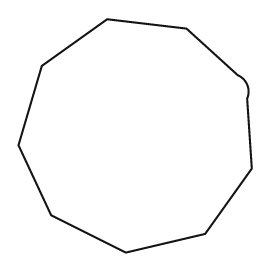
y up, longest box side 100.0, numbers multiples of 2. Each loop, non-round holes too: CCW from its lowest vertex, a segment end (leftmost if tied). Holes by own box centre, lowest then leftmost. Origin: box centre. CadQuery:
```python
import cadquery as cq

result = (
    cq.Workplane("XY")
    .moveTo(-4.0, -50.0)
    .lineTo(30.0, -42.0)
    .lineTo(50.0, -14.0)
    .lineTo(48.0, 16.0)
    .threePointArc((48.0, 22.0), (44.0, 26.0))
    .lineTo(22.0, 46.0)
    .lineTo(-12.0, 50.0)
    .lineTo(-40.0, 30.0)
    .lineTo(-50.0, -4.0)
    .lineTo(-36.0, -34.0)
    .close()
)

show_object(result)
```